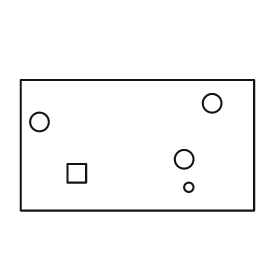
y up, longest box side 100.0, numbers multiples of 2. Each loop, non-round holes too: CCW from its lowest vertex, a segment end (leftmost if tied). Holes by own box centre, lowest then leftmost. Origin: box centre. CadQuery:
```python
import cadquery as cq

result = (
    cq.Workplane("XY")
    .moveTo(-50.0, -28.0)
    .lineTo(50.0, -28.0)
    .lineTo(50.0, 28.0)
    .lineTo(-50.0, 28.0)
    .close()
    .moveTo(22.0, -18.0)
    .circle(2.0)
    .moveTo(-30.0, -16.0)
    .lineTo(-22.0, -16.0)
    .lineTo(-22.0, -8.0)
    .lineTo(-30.0, -8.0)
    .close()
    .moveTo(20.0, -6.0)
    .circle(4.0)
    .moveTo(-42.0, 10.0)
    .circle(4.0)
    .moveTo(32.0, 18.0)
    .circle(4.0)
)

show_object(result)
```